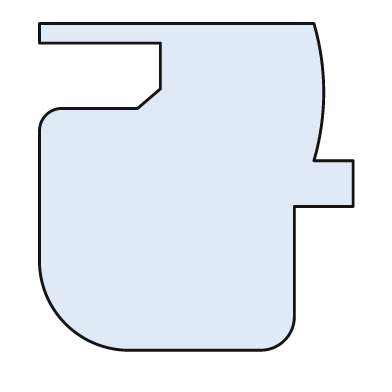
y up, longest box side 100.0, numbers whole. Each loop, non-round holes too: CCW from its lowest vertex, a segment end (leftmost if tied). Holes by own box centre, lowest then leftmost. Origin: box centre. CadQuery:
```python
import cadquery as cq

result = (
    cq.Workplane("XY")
    .moveTo(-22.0, -50.0)
    .lineTo(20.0, -50.0)
    .threePointArc((27.0, -47.0), (30.0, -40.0))
    .lineTo(30.0, -6.0)
    .lineTo(48.0, -6.0)
    .lineTo(48.0, 8.0)
    .lineTo(36.0, 8.0)
    .threePointArc((39.0, 29.0), (36.0, 50.0))
    .lineTo(-48.0, 50.0)
    .lineTo(-48.0, 44.0)
    .lineTo(-11.0, 44.0)
    .lineTo(-11.0, 30.0)
    .lineTo(-18.0, 24.0)
    .lineTo(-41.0, 24.0)
    .threePointArc((-46.0, 22.0), (-48.0, 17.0))
    .lineTo(-48.0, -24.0)
    .threePointArc((-40.0, -42.0), (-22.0, -50.0))
    .close()
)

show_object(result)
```